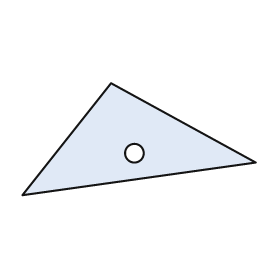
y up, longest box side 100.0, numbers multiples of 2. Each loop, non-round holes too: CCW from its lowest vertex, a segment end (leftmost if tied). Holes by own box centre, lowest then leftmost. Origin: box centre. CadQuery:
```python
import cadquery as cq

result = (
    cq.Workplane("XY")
    .moveTo(-50.0, -24.0)
    .lineTo(50.0, -10.0)
    .lineTo(-12.0, 24.0)
    .close()
    .moveTo(-2.0, -6.0)
    .circle(4.0)
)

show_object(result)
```